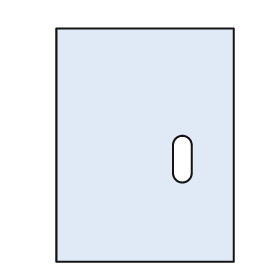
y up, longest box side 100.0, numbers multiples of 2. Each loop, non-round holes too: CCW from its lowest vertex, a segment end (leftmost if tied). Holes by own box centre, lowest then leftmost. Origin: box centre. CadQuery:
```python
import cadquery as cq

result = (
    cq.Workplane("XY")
    .moveTo(-38.0, -50.0)
    .lineTo(38.0, -50.0)
    .lineTo(38.0, 50.0)
    .lineTo(-38.0, 50.0)
    .close()
    .moveTo(12.0, -12.0)
    .threePointArc((16.0, -16.0), (20.0, -12.0))
    .lineTo(20.0, 0.0)
    .threePointArc((16.0, 4.0), (12.0, 0.0))
    .close()
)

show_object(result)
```